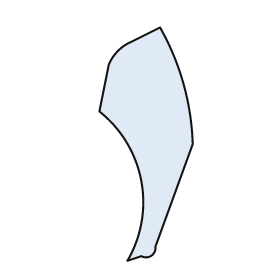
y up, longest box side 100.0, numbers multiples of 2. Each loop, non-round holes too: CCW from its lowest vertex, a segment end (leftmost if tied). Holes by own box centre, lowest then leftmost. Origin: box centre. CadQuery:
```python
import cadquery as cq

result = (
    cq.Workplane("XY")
    .moveTo(-8.0, -50.0)
    .lineTo(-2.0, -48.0)
    .threePointArc((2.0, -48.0), (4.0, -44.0))
    .lineTo(20.0, 0.0)
    .threePointArc((16.0, 26.0), (6.0, 50.0))
    .lineTo(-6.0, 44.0)
    .threePointArc((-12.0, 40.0), (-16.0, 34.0))
    .lineTo(-20.0, 14.0)
    .threePointArc((-2.0, -16.0), (-8.0, -50.0))
    .close()
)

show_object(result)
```